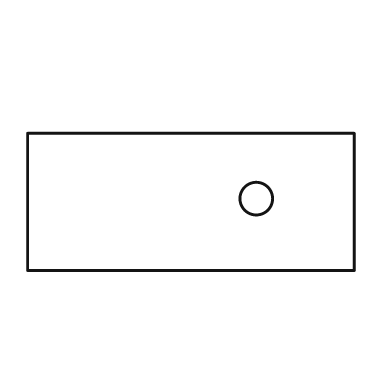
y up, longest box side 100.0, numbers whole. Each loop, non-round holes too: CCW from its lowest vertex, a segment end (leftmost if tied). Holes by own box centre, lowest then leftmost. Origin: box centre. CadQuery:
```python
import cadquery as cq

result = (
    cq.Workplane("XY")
    .moveTo(-50.0, -21.0)
    .lineTo(50.0, -21.0)
    .lineTo(50.0, 21.0)
    .lineTo(-50.0, 21.0)
    .close()
    .moveTo(20.0, 1.0)
    .circle(5.0)
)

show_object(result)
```